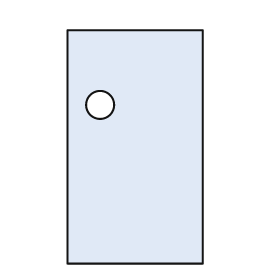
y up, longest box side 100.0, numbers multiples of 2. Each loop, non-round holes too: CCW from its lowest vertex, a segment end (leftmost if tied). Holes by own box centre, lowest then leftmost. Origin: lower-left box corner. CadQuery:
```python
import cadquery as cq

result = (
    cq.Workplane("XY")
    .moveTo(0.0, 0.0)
    .lineTo(58.0, 0.0)
    .lineTo(58.0, 100.0)
    .lineTo(0.0, 100.0)
    .close()
    .moveTo(14.0, 68.0)
    .circle(6.0)
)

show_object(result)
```